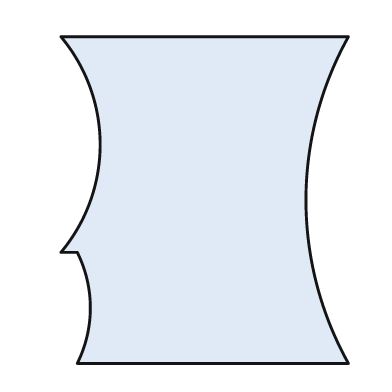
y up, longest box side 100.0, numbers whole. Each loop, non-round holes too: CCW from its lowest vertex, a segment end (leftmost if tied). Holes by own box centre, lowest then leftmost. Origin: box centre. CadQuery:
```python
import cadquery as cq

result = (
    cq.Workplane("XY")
    .moveTo(-39.0, -50.0)
    .lineTo(44.0, -50.0)
    .threePointArc((31.0, 0.0), (44.0, 50.0))
    .lineTo(-44.0, 50.0)
    .threePointArc((-32.0, 17.0), (-44.0, -16.0))
    .lineTo(-39.0, -16.0)
    .threePointArc((-35.0, -33.0), (-39.0, -50.0))
    .close()
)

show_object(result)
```